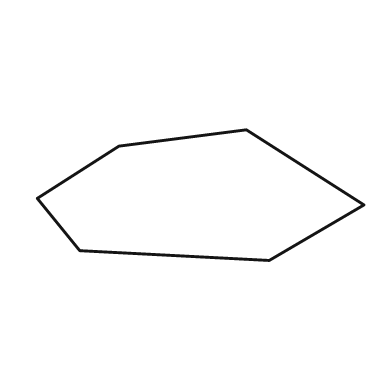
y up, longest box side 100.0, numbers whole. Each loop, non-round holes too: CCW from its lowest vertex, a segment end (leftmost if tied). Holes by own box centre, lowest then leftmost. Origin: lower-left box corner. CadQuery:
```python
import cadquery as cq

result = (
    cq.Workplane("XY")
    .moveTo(71.0, 0.0)
    .lineTo(100.0, 17.0)
    .lineTo(64.0, 40.0)
    .lineTo(25.0, 35.0)
    .lineTo(0.0, 19.0)
    .lineTo(13.0, 3.0)
    .close()
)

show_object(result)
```